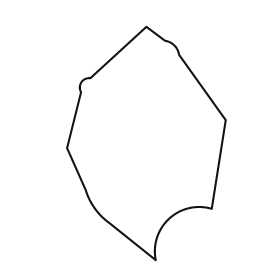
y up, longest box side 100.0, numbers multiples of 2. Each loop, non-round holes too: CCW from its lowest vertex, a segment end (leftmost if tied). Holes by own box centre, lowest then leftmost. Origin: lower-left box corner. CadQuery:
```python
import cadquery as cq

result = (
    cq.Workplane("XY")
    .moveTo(38.0, 0.0)
    .threePointArc((44.0, 18.0), (62.0, 22.0))
    .lineTo(68.0, 60.0)
    .lineTo(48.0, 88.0)
    .threePointArc((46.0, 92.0), (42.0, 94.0))
    .lineTo(34.0, 100.0)
    .lineTo(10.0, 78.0)
    .threePointArc((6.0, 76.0), (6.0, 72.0))
    .lineTo(0.0, 48.0)
    .lineTo(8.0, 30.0)
    .threePointArc((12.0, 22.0), (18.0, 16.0))
    .close()
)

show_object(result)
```